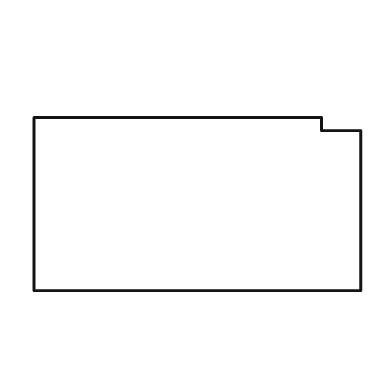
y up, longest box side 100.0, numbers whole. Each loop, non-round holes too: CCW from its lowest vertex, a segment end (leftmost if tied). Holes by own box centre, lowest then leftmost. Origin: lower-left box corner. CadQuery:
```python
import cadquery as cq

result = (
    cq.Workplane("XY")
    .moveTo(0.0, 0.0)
    .lineTo(100.0, 0.0)
    .lineTo(100.0, 49.0)
    .lineTo(88.0, 49.0)
    .lineTo(88.0, 53.0)
    .lineTo(0.0, 53.0)
    .close()
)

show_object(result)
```